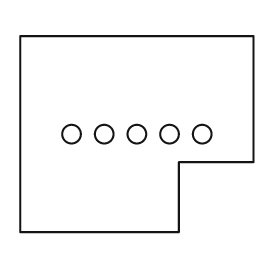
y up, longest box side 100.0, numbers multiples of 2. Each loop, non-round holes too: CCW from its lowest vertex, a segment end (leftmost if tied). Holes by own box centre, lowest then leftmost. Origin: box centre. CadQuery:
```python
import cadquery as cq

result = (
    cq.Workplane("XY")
    .moveTo(-50.0, -42.0)
    .lineTo(18.0, -42.0)
    .lineTo(18.0, -12.0)
    .lineTo(50.0, -12.0)
    .lineTo(50.0, 42.0)
    .lineTo(-50.0, 42.0)
    .close()
    .moveTo(-28.0, 0.0)
    .circle(4.0)
    .moveTo(-14.0, 0.0)
    .circle(4.0)
    .moveTo(0.0, 0.0)
    .circle(4.0)
    .moveTo(14.0, 0.0)
    .circle(4.0)
    .moveTo(28.0, 0.0)
    .circle(4.0)
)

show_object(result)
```